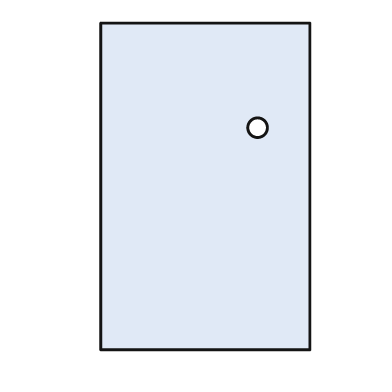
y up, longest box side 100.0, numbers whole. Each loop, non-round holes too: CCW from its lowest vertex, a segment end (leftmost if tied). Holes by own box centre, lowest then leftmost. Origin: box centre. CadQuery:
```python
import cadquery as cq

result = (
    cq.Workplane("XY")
    .moveTo(-32.0, -50.0)
    .lineTo(32.0, -50.0)
    .lineTo(32.0, 50.0)
    .lineTo(-32.0, 50.0)
    .close()
    .moveTo(16.0, 18.0)
    .circle(3.0)
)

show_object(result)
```